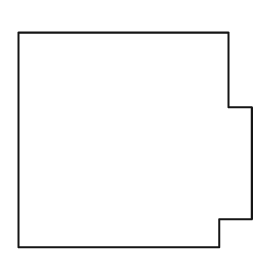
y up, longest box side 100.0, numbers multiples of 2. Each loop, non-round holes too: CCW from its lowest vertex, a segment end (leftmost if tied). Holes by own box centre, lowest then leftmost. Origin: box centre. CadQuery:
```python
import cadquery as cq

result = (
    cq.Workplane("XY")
    .moveTo(-50.0, -46.0)
    .lineTo(36.0, -46.0)
    .lineTo(36.0, -34.0)
    .lineTo(50.0, -34.0)
    .lineTo(50.0, 14.0)
    .lineTo(40.0, 14.0)
    .lineTo(40.0, 46.0)
    .lineTo(-50.0, 46.0)
    .close()
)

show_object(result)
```